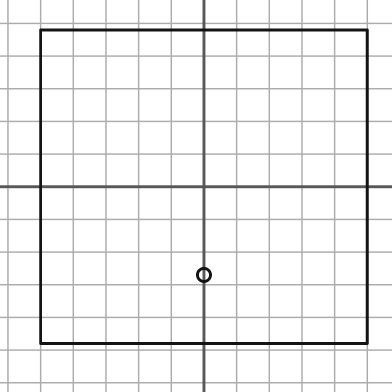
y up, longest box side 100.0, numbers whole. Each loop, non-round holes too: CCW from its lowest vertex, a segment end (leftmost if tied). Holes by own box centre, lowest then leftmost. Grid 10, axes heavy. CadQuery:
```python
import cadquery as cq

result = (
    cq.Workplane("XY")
    .moveTo(-50.0, -48.0)
    .lineTo(50.0, -48.0)
    .lineTo(50.0, 48.0)
    .lineTo(-50.0, 48.0)
    .close()
    .moveTo(0.0, -27.0)
    .circle(2.0)
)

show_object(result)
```